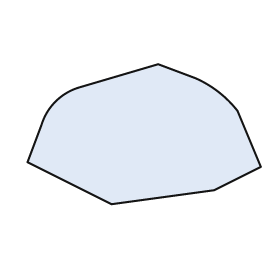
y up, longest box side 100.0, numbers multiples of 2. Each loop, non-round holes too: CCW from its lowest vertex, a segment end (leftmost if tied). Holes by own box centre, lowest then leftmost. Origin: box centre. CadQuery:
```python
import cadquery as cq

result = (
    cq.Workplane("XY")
    .moveTo(-14.0, -30.0)
    .lineTo(30.0, -24.0)
    .lineTo(50.0, -14.0)
    .lineTo(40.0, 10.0)
    .threePointArc((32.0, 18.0), (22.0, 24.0))
    .lineTo(6.0, 30.0)
    .lineTo(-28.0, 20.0)
    .threePointArc((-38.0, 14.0), (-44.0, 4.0))
    .lineTo(-50.0, -12.0)
    .close()
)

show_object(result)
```